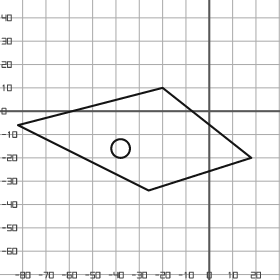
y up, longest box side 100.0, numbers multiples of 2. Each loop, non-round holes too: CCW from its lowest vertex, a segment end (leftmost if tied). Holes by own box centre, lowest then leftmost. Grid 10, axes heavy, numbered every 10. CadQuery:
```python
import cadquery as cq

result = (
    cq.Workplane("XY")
    .moveTo(-26.0, -34.0)
    .lineTo(18.0, -20.0)
    .lineTo(-20.0, 10.0)
    .lineTo(-82.0, -6.0)
    .close()
    .moveTo(-38.0, -16.0)
    .circle(4.0)
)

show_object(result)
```